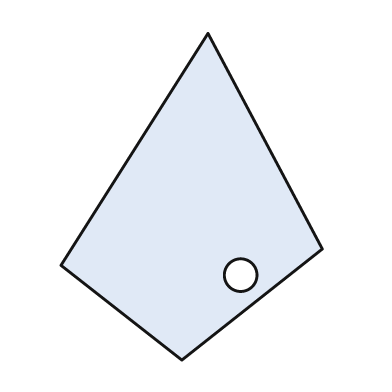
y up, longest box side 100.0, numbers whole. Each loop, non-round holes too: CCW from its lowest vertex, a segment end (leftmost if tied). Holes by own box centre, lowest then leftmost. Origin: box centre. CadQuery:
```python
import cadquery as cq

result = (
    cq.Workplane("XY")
    .moveTo(-3.0, -50.0)
    .lineTo(40.0, -16.0)
    .lineTo(5.0, 50.0)
    .lineTo(-40.0, -21.0)
    .close()
    .moveTo(15.0, -24.0)
    .circle(5.0)
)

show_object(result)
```